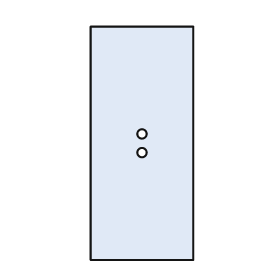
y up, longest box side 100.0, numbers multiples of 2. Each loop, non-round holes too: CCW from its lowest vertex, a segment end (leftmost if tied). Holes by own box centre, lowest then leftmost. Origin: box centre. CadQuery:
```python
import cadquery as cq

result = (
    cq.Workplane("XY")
    .moveTo(-22.0, -50.0)
    .lineTo(22.0, -50.0)
    .lineTo(22.0, 50.0)
    .lineTo(-22.0, 50.0)
    .close()
    .moveTo(0.0, -4.0)
    .circle(2.0)
    .moveTo(0.0, 4.0)
    .circle(2.0)
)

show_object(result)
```